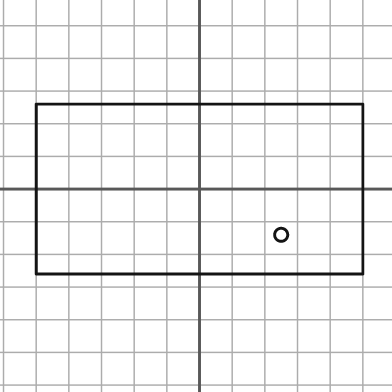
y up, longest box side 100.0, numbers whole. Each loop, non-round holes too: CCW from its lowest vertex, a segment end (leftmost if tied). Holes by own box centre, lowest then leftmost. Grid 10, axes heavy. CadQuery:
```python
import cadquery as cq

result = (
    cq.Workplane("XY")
    .moveTo(-50.0, -26.0)
    .lineTo(50.0, -26.0)
    .lineTo(50.0, 26.0)
    .lineTo(-50.0, 26.0)
    .close()
    .moveTo(25.0, -14.0)
    .circle(2.0)
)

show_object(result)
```